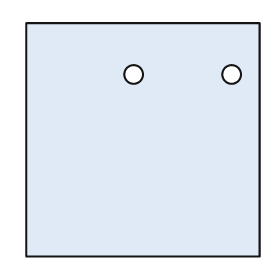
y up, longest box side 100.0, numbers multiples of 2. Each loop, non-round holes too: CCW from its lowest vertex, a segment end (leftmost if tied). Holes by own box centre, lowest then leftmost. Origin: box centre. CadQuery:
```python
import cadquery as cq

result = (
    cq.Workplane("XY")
    .moveTo(-50.0, -50.0)
    .lineTo(50.0, -50.0)
    .lineTo(50.0, 50.0)
    .lineTo(-50.0, 50.0)
    .close()
    .moveTo(-4.0, 28.0)
    .circle(4.0)
    .moveTo(38.0, 28.0)
    .circle(4.0)
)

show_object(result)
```